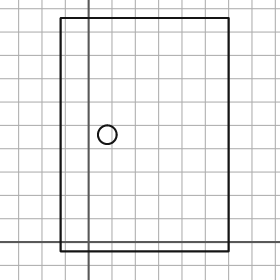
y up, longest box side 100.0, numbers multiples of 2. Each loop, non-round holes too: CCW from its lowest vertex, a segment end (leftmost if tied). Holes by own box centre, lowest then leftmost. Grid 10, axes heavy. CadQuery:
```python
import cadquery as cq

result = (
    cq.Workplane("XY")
    .moveTo(-12.0, -4.0)
    .lineTo(60.0, -4.0)
    .lineTo(60.0, 96.0)
    .lineTo(-12.0, 96.0)
    .close()
    .moveTo(8.0, 46.0)
    .circle(4.0)
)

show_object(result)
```